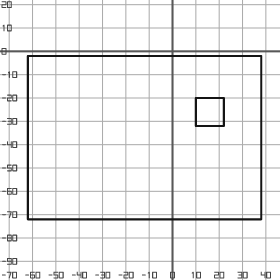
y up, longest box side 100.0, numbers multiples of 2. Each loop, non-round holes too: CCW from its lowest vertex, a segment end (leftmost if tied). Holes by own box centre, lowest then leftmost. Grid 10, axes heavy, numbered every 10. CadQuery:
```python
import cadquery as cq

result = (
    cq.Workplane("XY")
    .moveTo(-62.0, -72.0)
    .lineTo(38.0, -72.0)
    .lineTo(38.0, -2.0)
    .lineTo(-62.0, -2.0)
    .close()
    .moveTo(10.0, -32.0)
    .lineTo(22.0, -32.0)
    .lineTo(22.0, -20.0)
    .lineTo(10.0, -20.0)
    .close()
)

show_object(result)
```